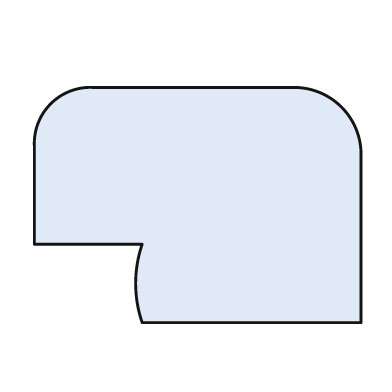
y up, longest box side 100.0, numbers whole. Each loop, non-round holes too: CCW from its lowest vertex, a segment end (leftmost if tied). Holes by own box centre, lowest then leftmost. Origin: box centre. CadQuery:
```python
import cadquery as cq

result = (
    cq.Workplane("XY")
    .moveTo(-17.0, -36.0)
    .lineTo(50.0, -36.0)
    .lineTo(50.0, 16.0)
    .threePointArc((44.0, 30.0), (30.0, 36.0))
    .lineTo(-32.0, 36.0)
    .threePointArc((-45.0, 31.0), (-50.0, 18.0))
    .lineTo(-50.0, -12.0)
    .lineTo(-17.0, -12.0)
    .threePointArc((-19.0, -24.0), (-17.0, -36.0))
    .close()
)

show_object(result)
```